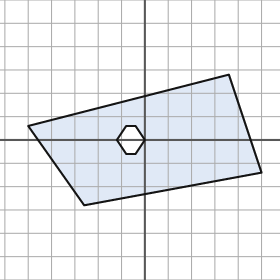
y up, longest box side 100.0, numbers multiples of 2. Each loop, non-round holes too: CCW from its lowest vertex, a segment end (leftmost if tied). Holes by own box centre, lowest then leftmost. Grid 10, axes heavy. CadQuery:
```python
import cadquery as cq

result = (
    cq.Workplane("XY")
    .moveTo(-26.0, -28.0)
    .lineTo(50.0, -14.0)
    .lineTo(36.0, 28.0)
    .lineTo(-50.0, 6.0)
    .close()
    .moveTo(-8.0, -6.0)
    .lineTo(-4.0, -6.0)
    .lineTo(0.0, 0.0)
    .lineTo(-4.0, 6.0)
    .lineTo(-8.0, 6.0)
    .lineTo(-12.0, 0.0)
    .close()
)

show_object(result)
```